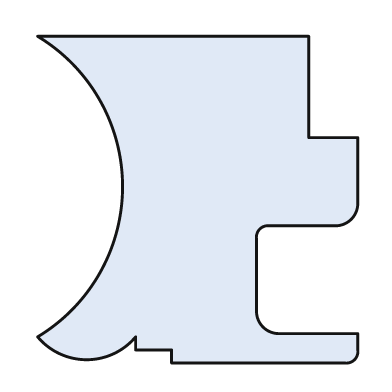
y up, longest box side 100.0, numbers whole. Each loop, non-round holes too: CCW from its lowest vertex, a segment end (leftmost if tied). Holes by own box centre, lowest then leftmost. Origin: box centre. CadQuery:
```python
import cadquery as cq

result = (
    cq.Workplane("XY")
    .moveTo(-8.0, -50.0)
    .lineTo(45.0, -50.0)
    .threePointArc((48.0, -49.0), (49.0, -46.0))
    .lineTo(49.0, -41.0)
    .lineTo(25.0, -41.0)
    .threePointArc((20.0, -39.0), (18.0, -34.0))
    .lineTo(18.0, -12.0)
    .threePointArc((19.0, -9.0), (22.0, -8.0))
    .lineTo(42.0, -8.0)
    .threePointArc((47.0, -6.0), (49.0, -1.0))
    .lineTo(49.0, 19.0)
    .lineTo(34.0, 19.0)
    .lineTo(34.0, 50.0)
    .lineTo(-49.0, 50.0)
    .threePointArc((-23.0, 4.0), (-49.0, -42.0))
    .threePointArc((-34.0, -49.0), (-19.0, -42.0))
    .lineTo(-19.0, -46.0)
    .lineTo(-8.0, -46.0)
    .close()
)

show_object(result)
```